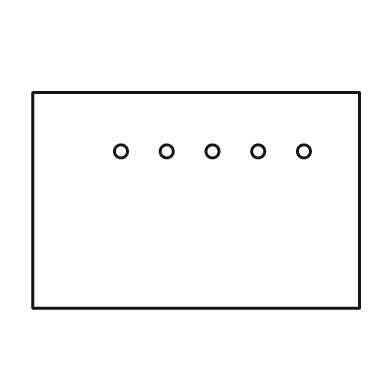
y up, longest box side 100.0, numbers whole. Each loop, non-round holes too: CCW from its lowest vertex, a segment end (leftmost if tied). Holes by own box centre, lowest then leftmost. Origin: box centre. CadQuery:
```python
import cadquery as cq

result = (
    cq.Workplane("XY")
    .moveTo(-50.0, -33.0)
    .lineTo(50.0, -33.0)
    .lineTo(50.0, 33.0)
    .lineTo(-50.0, 33.0)
    .close()
    .moveTo(-23.0, 15.0)
    .circle(2.0)
    .moveTo(-9.0, 15.0)
    .circle(2.0)
    .moveTo(5.0, 15.0)
    .circle(2.0)
    .moveTo(19.0, 15.0)
    .circle(2.0)
    .moveTo(33.0, 15.0)
    .circle(2.0)
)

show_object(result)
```